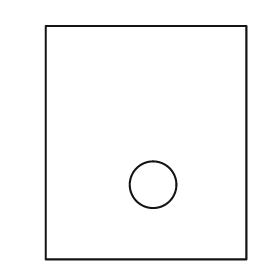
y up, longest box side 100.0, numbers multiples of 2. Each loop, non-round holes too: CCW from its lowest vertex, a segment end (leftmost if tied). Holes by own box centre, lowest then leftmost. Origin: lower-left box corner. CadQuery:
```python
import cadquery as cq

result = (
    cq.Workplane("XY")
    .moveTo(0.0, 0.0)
    .lineTo(86.0, 0.0)
    .lineTo(86.0, 100.0)
    .lineTo(0.0, 100.0)
    .close()
    .moveTo(46.0, 32.0)
    .circle(10.0)
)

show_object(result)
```